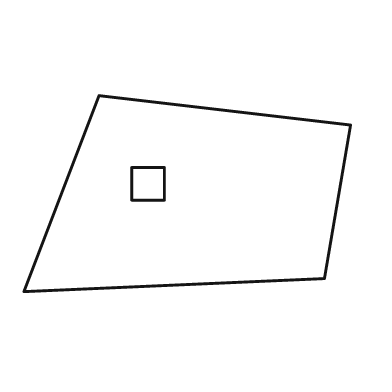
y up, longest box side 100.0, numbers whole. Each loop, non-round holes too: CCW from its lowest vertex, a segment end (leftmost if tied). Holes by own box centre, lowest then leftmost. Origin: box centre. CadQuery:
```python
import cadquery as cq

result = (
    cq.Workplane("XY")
    .moveTo(-50.0, -30.0)
    .lineTo(42.0, -26.0)
    .lineTo(50.0, 21.0)
    .lineTo(-27.0, 30.0)
    .close()
    .moveTo(-17.0, -2.0)
    .lineTo(-7.0, -2.0)
    .lineTo(-7.0, 8.0)
    .lineTo(-17.0, 8.0)
    .close()
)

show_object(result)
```